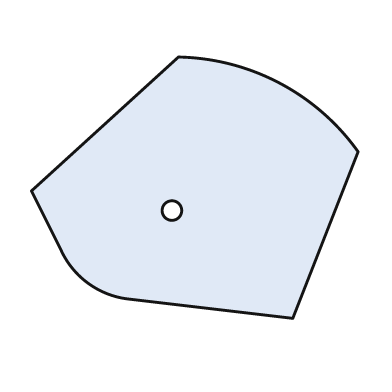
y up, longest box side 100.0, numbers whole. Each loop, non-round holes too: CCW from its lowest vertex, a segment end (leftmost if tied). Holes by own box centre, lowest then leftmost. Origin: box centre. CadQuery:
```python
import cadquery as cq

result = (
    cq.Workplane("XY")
    .moveTo(30.0, -40.0)
    .lineTo(50.0, 11.0)
    .threePointArc((26.0, 32.0), (-5.0, 40.0))
    .lineTo(-50.0, -1.0)
    .lineTo(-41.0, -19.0)
    .threePointArc((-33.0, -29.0), (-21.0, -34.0))
    .close()
    .moveTo(-7.0, -7.0)
    .circle(3.0)
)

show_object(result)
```